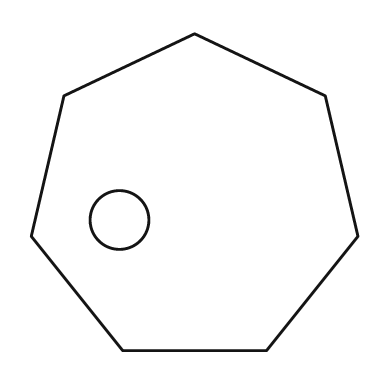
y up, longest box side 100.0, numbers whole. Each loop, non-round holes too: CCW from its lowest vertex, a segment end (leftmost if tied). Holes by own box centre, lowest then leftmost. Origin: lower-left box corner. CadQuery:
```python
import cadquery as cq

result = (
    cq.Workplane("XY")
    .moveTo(28.0, 0.0)
    .lineTo(72.0, 0.0)
    .lineTo(100.0, 35.0)
    .lineTo(90.0, 78.0)
    .lineTo(50.0, 97.0)
    .lineTo(10.0, 78.0)
    .lineTo(0.0, 35.0)
    .close()
    .moveTo(27.0, 40.0)
    .circle(9.0)
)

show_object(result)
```